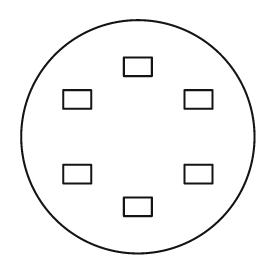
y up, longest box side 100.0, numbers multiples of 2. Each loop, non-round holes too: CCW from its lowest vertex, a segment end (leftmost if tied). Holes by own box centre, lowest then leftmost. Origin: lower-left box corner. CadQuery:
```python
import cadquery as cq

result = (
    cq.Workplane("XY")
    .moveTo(50.0, 50.0)
    .circle(50.0)
    .moveTo(44.0, 16.0)
    .lineTo(56.0, 16.0)
    .lineTo(56.0, 24.0)
    .lineTo(44.0, 24.0)
    .close()
    .moveTo(18.0, 30.0)
    .lineTo(30.0, 30.0)
    .lineTo(30.0, 38.0)
    .lineTo(18.0, 38.0)
    .close()
    .moveTo(70.0, 30.0)
    .lineTo(82.0, 30.0)
    .lineTo(82.0, 38.0)
    .lineTo(70.0, 38.0)
    .close()
    .moveTo(18.0, 62.0)
    .lineTo(30.0, 62.0)
    .lineTo(30.0, 70.0)
    .lineTo(18.0, 70.0)
    .close()
    .moveTo(70.0, 62.0)
    .lineTo(82.0, 62.0)
    .lineTo(82.0, 70.0)
    .lineTo(70.0, 70.0)
    .close()
    .moveTo(44.0, 76.0)
    .lineTo(56.0, 76.0)
    .lineTo(56.0, 84.0)
    .lineTo(44.0, 84.0)
    .close()
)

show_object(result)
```